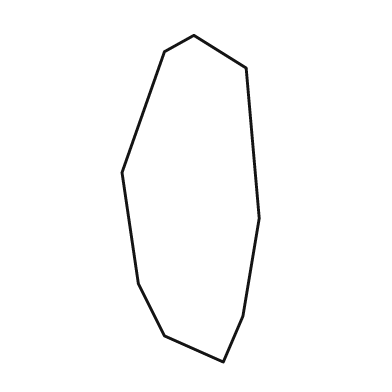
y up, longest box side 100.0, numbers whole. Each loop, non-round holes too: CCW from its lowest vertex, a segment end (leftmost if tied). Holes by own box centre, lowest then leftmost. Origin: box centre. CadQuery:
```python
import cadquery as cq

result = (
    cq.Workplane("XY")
    .moveTo(10.0, -50.0)
    .lineTo(16.0, -36.0)
    .lineTo(21.0, -6.0)
    .lineTo(17.0, 40.0)
    .lineTo(1.0, 50.0)
    .lineTo(-8.0, 45.0)
    .lineTo(-21.0, 8.0)
    .lineTo(-16.0, -26.0)
    .lineTo(-8.0, -42.0)
    .close()
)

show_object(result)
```